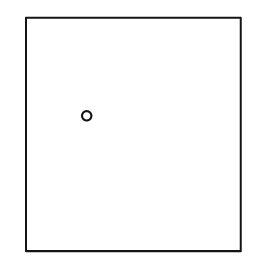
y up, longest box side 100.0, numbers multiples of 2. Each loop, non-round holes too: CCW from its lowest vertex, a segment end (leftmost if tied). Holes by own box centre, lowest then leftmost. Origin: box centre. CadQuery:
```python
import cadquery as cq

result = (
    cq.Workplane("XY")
    .moveTo(-46.0, -50.0)
    .lineTo(46.0, -50.0)
    .lineTo(46.0, 50.0)
    .lineTo(-46.0, 50.0)
    .close()
    .moveTo(-20.0, 8.0)
    .circle(2.0)
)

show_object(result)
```